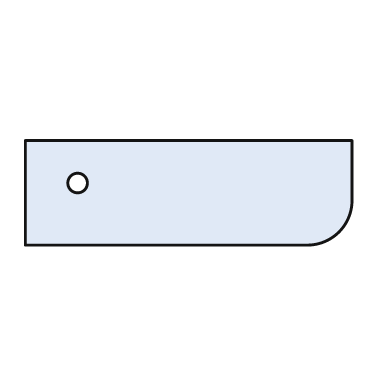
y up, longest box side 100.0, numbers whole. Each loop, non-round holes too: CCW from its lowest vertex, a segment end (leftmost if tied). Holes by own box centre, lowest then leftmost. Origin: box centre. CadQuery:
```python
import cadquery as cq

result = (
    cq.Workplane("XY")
    .moveTo(-50.0, -16.0)
    .lineTo(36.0, -16.0)
    .threePointArc((46.0, -12.0), (50.0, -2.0))
    .lineTo(50.0, 16.0)
    .lineTo(-50.0, 16.0)
    .close()
    .moveTo(-34.0, 3.0)
    .circle(3.0)
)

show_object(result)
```